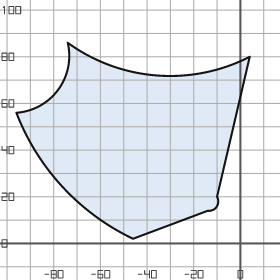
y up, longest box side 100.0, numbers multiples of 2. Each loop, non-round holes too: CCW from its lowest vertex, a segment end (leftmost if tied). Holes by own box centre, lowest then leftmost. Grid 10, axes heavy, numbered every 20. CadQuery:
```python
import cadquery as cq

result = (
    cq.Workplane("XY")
    .moveTo(-46.0, 2.0)
    .lineTo(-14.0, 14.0)
    .threePointArc((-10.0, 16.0), (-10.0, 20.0))
    .lineTo(4.0, 80.0)
    .threePointArc((-36.0, 72.0), (-74.0, 86.0))
    .threePointArc((-78.0, 66.0), (-96.0, 56.0))
    .threePointArc((-76.0, 24.0), (-46.0, 2.0))
    .close()
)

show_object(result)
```